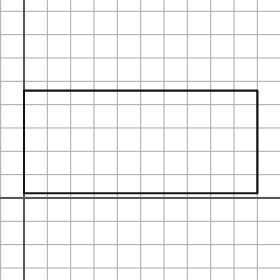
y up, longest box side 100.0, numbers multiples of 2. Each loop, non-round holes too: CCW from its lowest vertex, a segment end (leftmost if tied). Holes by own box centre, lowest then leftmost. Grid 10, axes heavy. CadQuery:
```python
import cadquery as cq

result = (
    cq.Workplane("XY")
    .moveTo(0.0, 2.0)
    .lineTo(100.0, 2.0)
    .lineTo(100.0, 46.0)
    .lineTo(0.0, 46.0)
    .close()
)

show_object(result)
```